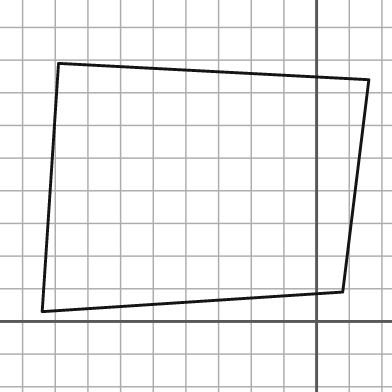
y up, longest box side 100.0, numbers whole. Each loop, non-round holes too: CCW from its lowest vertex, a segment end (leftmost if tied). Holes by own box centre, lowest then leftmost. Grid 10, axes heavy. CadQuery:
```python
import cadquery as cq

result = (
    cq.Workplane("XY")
    .moveTo(-84.0, 3.0)
    .lineTo(8.0, 9.0)
    .lineTo(16.0, 74.0)
    .lineTo(-79.0, 79.0)
    .close()
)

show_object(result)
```